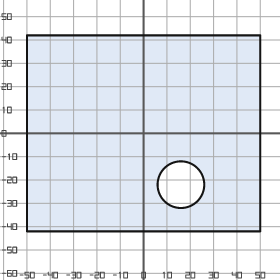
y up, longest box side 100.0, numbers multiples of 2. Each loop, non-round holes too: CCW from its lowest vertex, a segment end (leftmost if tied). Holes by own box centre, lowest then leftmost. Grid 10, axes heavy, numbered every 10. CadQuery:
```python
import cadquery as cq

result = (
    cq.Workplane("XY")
    .moveTo(-50.0, -42.0)
    .lineTo(50.0, -42.0)
    .lineTo(50.0, 42.0)
    .lineTo(-50.0, 42.0)
    .close()
    .moveTo(16.0, -22.0)
    .circle(10.0)
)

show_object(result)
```